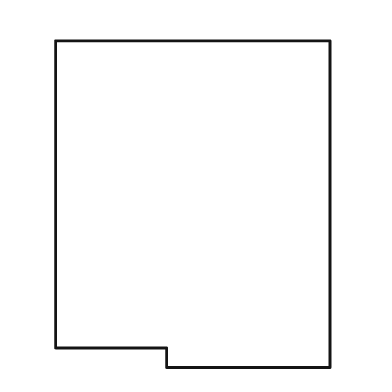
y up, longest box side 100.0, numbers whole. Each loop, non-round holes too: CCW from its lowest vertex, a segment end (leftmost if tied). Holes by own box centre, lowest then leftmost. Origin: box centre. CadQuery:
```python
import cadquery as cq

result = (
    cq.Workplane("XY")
    .moveTo(-8.0, -50.0)
    .lineTo(42.0, -50.0)
    .lineTo(42.0, 50.0)
    .lineTo(-42.0, 50.0)
    .lineTo(-42.0, -44.0)
    .lineTo(-8.0, -44.0)
    .close()
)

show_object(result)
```